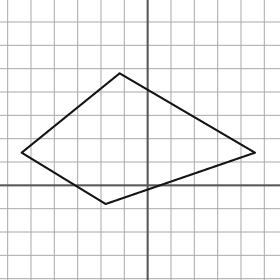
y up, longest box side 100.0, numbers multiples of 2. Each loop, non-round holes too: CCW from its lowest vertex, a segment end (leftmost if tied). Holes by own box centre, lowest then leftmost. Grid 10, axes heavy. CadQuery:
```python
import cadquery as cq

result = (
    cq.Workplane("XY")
    .moveTo(-18.0, -8.0)
    .lineTo(46.0, 14.0)
    .lineTo(-12.0, 48.0)
    .lineTo(-54.0, 14.0)
    .close()
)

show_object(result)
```